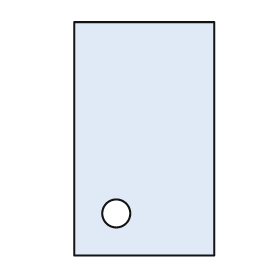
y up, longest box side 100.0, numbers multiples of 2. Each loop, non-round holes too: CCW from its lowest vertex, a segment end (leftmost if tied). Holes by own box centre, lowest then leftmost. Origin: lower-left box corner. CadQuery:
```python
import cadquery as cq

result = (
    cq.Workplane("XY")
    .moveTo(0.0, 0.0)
    .lineTo(60.0, 0.0)
    .lineTo(60.0, 100.0)
    .lineTo(0.0, 100.0)
    .close()
    .moveTo(18.0, 18.0)
    .circle(6.0)
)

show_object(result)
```